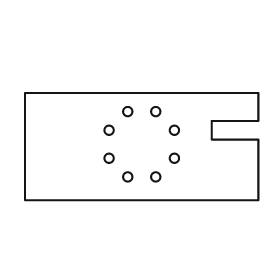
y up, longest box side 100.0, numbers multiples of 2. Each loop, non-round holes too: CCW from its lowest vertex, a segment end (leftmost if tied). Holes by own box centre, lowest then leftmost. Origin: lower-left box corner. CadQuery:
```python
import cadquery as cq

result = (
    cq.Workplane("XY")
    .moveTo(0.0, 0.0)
    .lineTo(100.0, 0.0)
    .lineTo(100.0, 26.0)
    .lineTo(80.0, 26.0)
    .lineTo(80.0, 34.0)
    .lineTo(100.0, 34.0)
    .lineTo(100.0, 46.0)
    .lineTo(0.0, 46.0)
    .close()
    .moveTo(44.0, 10.0)
    .circle(2.0)
    .moveTo(56.0, 10.0)
    .circle(2.0)
    .moveTo(36.0, 18.0)
    .circle(2.0)
    .moveTo(64.0, 18.0)
    .circle(2.0)
    .moveTo(36.0, 30.0)
    .circle(2.0)
    .moveTo(64.0, 30.0)
    .circle(2.0)
    .moveTo(44.0, 38.0)
    .circle(2.0)
    .moveTo(56.0, 38.0)
    .circle(2.0)
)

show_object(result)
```